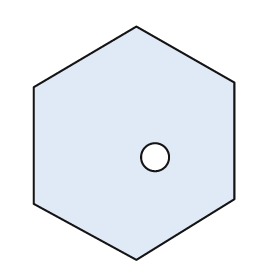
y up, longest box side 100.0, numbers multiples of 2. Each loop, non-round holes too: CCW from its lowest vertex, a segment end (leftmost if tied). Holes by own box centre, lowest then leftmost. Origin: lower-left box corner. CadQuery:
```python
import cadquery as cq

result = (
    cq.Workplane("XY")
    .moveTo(44.0, 0.0)
    .lineTo(86.0, 26.0)
    .lineTo(86.0, 76.0)
    .lineTo(44.0, 100.0)
    .lineTo(0.0, 74.0)
    .lineTo(0.0, 24.0)
    .close()
    .moveTo(52.0, 44.0)
    .circle(6.0)
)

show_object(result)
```